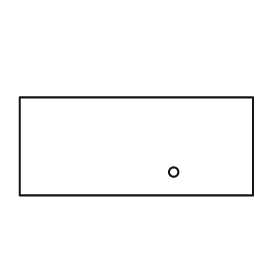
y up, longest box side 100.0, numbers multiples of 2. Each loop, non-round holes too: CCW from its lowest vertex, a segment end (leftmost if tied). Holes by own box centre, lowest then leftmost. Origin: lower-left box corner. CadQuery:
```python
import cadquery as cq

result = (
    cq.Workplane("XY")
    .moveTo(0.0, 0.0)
    .lineTo(100.0, 0.0)
    .lineTo(100.0, 42.0)
    .lineTo(0.0, 42.0)
    .close()
    .moveTo(66.0, 10.0)
    .circle(2.0)
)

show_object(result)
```